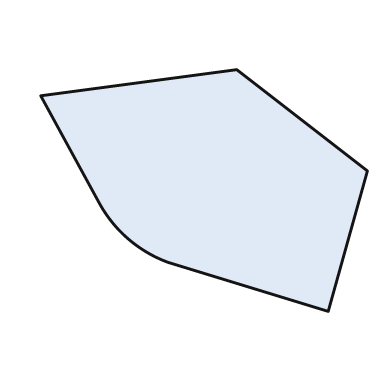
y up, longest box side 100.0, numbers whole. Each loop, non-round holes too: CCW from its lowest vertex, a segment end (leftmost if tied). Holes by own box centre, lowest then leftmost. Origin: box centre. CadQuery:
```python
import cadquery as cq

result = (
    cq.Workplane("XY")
    .moveTo(38.0, -37.0)
    .lineTo(50.0, 6.0)
    .lineTo(10.0, 37.0)
    .lineTo(-50.0, 29.0)
    .lineTo(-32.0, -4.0)
    .threePointArc((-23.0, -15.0), (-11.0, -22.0))
    .close()
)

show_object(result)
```